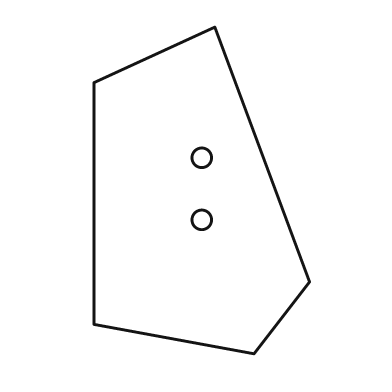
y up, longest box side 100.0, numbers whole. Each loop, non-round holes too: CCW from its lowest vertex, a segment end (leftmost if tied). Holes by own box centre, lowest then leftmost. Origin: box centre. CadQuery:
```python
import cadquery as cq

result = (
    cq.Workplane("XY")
    .moveTo(16.0, -50.0)
    .lineTo(33.0, -28.0)
    .lineTo(4.0, 50.0)
    .lineTo(-33.0, 33.0)
    .lineTo(-33.0, -41.0)
    .close()
    .moveTo(0.0, -9.0)
    .circle(3.0)
    .moveTo(0.0, 10.0)
    .circle(3.0)
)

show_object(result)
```